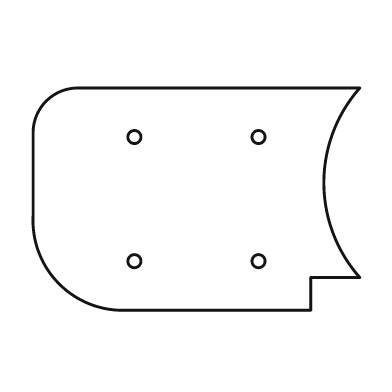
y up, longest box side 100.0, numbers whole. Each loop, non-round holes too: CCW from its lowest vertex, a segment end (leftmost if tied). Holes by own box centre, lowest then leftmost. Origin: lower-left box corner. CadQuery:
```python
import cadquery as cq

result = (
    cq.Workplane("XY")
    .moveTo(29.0, 0.0)
    .lineTo(85.0, 0.0)
    .lineTo(85.0, 10.0)
    .lineTo(100.0, 10.0)
    .threePointArc((89.0, 39.0), (100.0, 68.0))
    .lineTo(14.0, 68.0)
    .threePointArc((4.0, 64.0), (0.0, 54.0))
    .lineTo(0.0, 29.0)
    .threePointArc((8.0, 8.0), (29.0, 0.0))
    .close()
    .moveTo(31.0, 15.0)
    .circle(2.0)
    .moveTo(69.0, 15.0)
    .circle(2.0)
    .moveTo(31.0, 53.0)
    .circle(2.0)
    .moveTo(69.0, 53.0)
    .circle(2.0)
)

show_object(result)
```